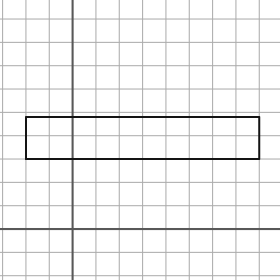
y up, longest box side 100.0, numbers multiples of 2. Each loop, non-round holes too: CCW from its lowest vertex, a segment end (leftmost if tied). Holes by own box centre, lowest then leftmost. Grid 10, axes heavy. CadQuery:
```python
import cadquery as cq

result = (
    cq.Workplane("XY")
    .moveTo(-20.0, 30.0)
    .lineTo(80.0, 30.0)
    .lineTo(80.0, 48.0)
    .lineTo(-20.0, 48.0)
    .close()
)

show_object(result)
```